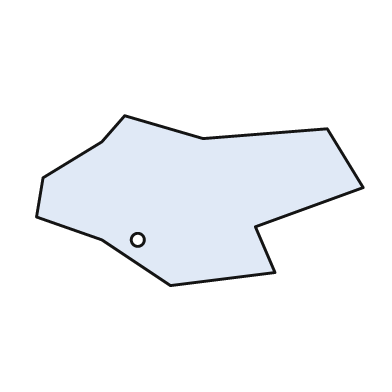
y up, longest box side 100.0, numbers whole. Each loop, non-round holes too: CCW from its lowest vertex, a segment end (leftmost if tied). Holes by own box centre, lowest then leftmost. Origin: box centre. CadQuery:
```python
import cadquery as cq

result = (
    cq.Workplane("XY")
    .moveTo(-9.0, -26.0)
    .lineTo(23.0, -22.0)
    .lineTo(17.0, -8.0)
    .lineTo(50.0, 4.0)
    .lineTo(39.0, 22.0)
    .lineTo(1.0, 19.0)
    .lineTo(-23.0, 26.0)
    .lineTo(-30.0, 18.0)
    .lineTo(-48.0, 7.0)
    .lineTo(-50.0, -5.0)
    .lineTo(-30.0, -12.0)
    .close()
    .moveTo(-19.0, -12.0)
    .circle(2.0)
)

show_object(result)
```